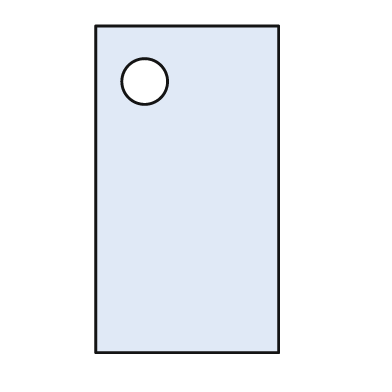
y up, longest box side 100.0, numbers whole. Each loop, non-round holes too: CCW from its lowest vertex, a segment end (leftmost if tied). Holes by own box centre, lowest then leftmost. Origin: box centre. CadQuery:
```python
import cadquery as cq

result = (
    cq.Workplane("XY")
    .moveTo(-28.0, -50.0)
    .lineTo(28.0, -50.0)
    .lineTo(28.0, 50.0)
    .lineTo(-28.0, 50.0)
    .close()
    .moveTo(-13.0, 33.0)
    .circle(7.0)
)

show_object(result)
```